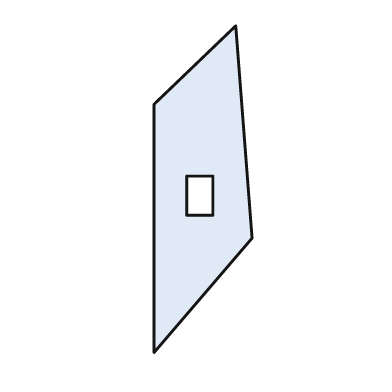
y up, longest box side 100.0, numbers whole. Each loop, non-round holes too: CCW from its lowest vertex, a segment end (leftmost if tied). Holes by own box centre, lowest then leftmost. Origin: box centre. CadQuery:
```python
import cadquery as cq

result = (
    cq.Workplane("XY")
    .moveTo(-15.0, -50.0)
    .lineTo(15.0, -15.0)
    .lineTo(10.0, 50.0)
    .lineTo(-15.0, 26.0)
    .close()
    .moveTo(-5.0, -8.0)
    .lineTo(3.0, -8.0)
    .lineTo(3.0, 4.0)
    .lineTo(-5.0, 4.0)
    .close()
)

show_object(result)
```